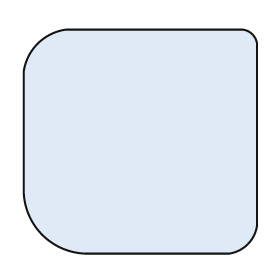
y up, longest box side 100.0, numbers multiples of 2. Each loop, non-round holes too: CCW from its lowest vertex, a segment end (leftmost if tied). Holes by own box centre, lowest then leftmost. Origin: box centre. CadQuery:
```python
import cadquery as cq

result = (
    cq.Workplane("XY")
    .moveTo(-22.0, -48.0)
    .lineTo(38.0, -48.0)
    .threePointArc((46.0, -44.0), (50.0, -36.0))
    .lineTo(50.0, 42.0)
    .threePointArc((48.0, 46.0), (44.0, 48.0))
    .lineTo(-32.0, 48.0)
    .threePointArc((-44.0, 42.0), (-50.0, 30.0))
    .lineTo(-50.0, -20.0)
    .threePointArc((-42.0, -40.0), (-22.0, -48.0))
    .close()
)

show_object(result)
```